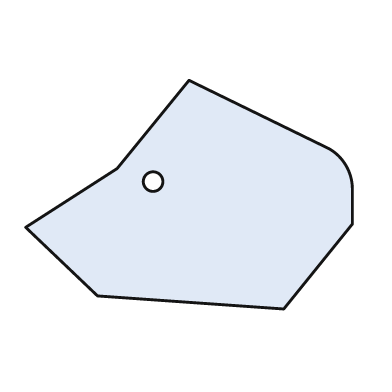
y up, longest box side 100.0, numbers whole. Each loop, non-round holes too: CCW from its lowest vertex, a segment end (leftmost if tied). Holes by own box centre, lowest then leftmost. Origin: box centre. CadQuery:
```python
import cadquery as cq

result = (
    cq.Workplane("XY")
    .moveTo(29.0, -35.0)
    .lineTo(50.0, -9.0)
    .lineTo(50.0, 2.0)
    .threePointArc((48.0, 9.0), (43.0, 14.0))
    .lineTo(0.0, 35.0)
    .lineTo(-22.0, 8.0)
    .lineTo(-50.0, -10.0)
    .lineTo(-28.0, -31.0)
    .close()
    .moveTo(-11.0, 4.0)
    .circle(3.0)
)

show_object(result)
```